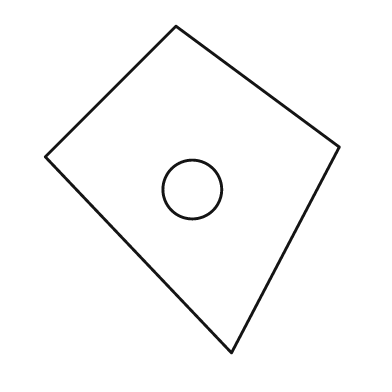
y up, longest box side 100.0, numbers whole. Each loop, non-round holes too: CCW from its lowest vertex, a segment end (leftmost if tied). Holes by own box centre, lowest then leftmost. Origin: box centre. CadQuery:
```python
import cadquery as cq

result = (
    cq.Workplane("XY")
    .moveTo(12.0, -50.0)
    .lineTo(45.0, 13.0)
    .lineTo(-5.0, 50.0)
    .lineTo(-45.0, 10.0)
    .close()
    .moveTo(0.0, 0.0)
    .circle(9.0)
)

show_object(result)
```